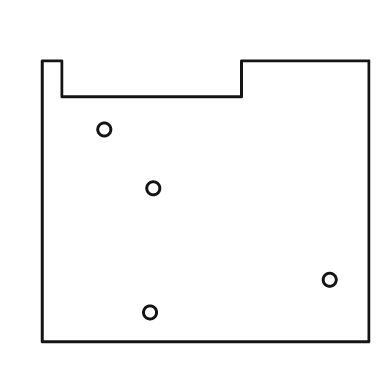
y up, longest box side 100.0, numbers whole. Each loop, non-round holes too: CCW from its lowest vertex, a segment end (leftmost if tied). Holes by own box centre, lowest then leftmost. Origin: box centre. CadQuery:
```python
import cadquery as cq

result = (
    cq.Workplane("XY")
    .moveTo(-50.0, -43.0)
    .lineTo(50.0, -43.0)
    .lineTo(50.0, 43.0)
    .lineTo(11.0, 43.0)
    .lineTo(11.0, 32.0)
    .lineTo(-44.0, 32.0)
    .lineTo(-44.0, 43.0)
    .lineTo(-50.0, 43.0)
    .close()
    .moveTo(-17.0, -34.0)
    .circle(2.0)
    .moveTo(38.0, -24.0)
    .circle(2.0)
    .moveTo(-16.0, 4.0)
    .circle(2.0)
    .moveTo(-31.0, 22.0)
    .circle(2.0)
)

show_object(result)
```